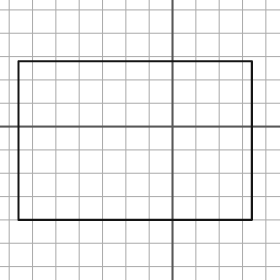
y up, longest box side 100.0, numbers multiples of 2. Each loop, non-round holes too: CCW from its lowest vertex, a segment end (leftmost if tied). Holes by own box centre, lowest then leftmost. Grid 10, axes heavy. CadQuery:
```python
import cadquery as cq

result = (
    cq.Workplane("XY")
    .moveTo(-66.0, -40.0)
    .lineTo(34.0, -40.0)
    .lineTo(34.0, 28.0)
    .lineTo(-66.0, 28.0)
    .close()
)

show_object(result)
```